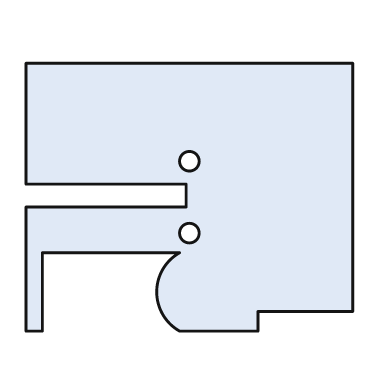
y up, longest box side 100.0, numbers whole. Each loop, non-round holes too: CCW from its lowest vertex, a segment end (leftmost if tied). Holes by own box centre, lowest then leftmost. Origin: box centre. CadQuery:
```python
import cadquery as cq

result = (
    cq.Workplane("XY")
    .moveTo(-50.0, -41.0)
    .lineTo(-45.0, -41.0)
    .lineTo(-45.0, -17.0)
    .lineTo(-3.0, -17.0)
    .threePointArc((-10.0, -29.0), (-3.0, -41.0))
    .lineTo(21.0, -41.0)
    .lineTo(21.0, -35.0)
    .lineTo(50.0, -35.0)
    .lineTo(50.0, 41.0)
    .lineTo(-50.0, 41.0)
    .lineTo(-50.0, 4.0)
    .lineTo(-1.0, 4.0)
    .lineTo(-1.0, -3.0)
    .lineTo(-50.0, -3.0)
    .close()
    .moveTo(0.0, -11.0)
    .circle(3.0)
    .moveTo(0.0, 11.0)
    .circle(3.0)
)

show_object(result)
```